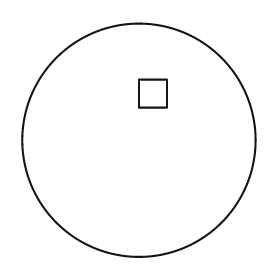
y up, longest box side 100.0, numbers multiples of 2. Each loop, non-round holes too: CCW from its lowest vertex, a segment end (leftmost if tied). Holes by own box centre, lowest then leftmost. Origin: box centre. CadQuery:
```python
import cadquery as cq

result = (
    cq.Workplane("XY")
    .moveTo(0.0, 0.0)
    .circle(50.0)
    .moveTo(0.0, 14.0)
    .lineTo(12.0, 14.0)
    .lineTo(12.0, 26.0)
    .lineTo(0.0, 26.0)
    .close()
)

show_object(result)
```